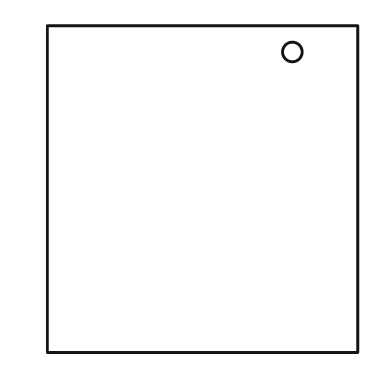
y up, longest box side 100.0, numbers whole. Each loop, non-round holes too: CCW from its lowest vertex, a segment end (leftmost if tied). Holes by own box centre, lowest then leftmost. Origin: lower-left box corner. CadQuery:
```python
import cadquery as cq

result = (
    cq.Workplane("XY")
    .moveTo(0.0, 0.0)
    .lineTo(95.0, 0.0)
    .lineTo(95.0, 100.0)
    .lineTo(0.0, 100.0)
    .close()
    .moveTo(75.0, 92.0)
    .circle(3.0)
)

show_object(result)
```